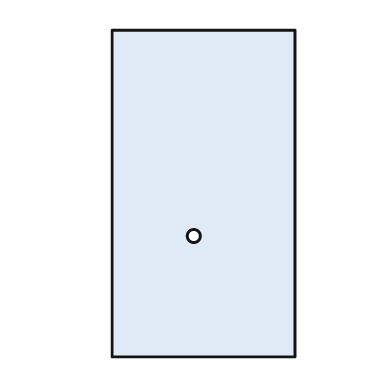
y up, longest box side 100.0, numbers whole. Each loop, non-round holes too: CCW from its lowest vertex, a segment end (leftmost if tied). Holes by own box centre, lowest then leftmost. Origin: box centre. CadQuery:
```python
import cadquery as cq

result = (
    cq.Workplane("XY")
    .moveTo(-28.0, -50.0)
    .lineTo(28.0, -50.0)
    .lineTo(28.0, 50.0)
    .lineTo(-28.0, 50.0)
    .close()
    .moveTo(-3.0, -13.0)
    .circle(2.0)
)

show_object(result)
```